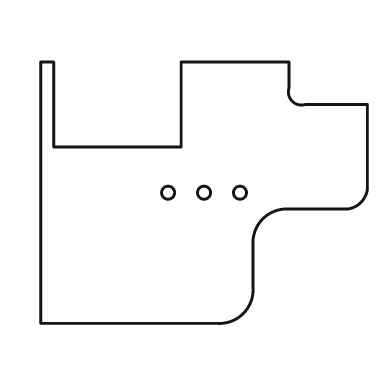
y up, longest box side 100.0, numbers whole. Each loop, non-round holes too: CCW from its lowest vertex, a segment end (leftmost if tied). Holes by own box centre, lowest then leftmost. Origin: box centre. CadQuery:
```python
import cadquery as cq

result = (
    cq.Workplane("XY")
    .moveTo(-50.0, -40.0)
    .lineTo(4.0, -40.0)
    .threePointArc((12.0, -37.0), (15.0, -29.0))
    .lineTo(15.0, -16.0)
    .threePointArc((18.0, -8.0), (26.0, -5.0))
    .lineTo(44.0, -5.0)
    .threePointArc((48.0, -3.0), (50.0, 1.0))
    .lineTo(50.0, 27.0)
    .lineTo(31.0, 27.0)
    .threePointArc((27.0, 28.0), (26.0, 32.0))
    .lineTo(26.0, 40.0)
    .lineTo(-7.0, 40.0)
    .lineTo(-7.0, 14.0)
    .lineTo(-46.0, 14.0)
    .lineTo(-46.0, 40.0)
    .lineTo(-50.0, 40.0)
    .close()
    .moveTo(-11.0, 0.0)
    .circle(2.0)
    .moveTo(0.0, 0.0)
    .circle(2.0)
    .moveTo(11.0, 0.0)
    .circle(2.0)
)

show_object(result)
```